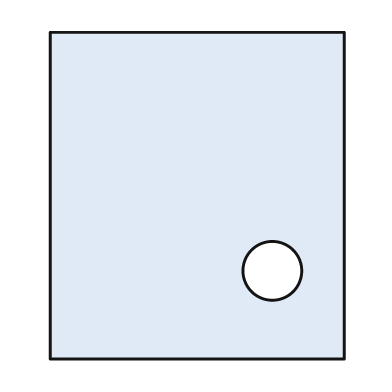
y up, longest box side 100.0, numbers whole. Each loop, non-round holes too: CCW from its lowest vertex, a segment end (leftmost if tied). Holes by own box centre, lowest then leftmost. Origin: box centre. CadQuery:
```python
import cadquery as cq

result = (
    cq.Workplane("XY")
    .moveTo(-45.0, -50.0)
    .lineTo(45.0, -50.0)
    .lineTo(45.0, 50.0)
    .lineTo(-45.0, 50.0)
    .close()
    .moveTo(23.0, -23.0)
    .circle(9.0)
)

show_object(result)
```